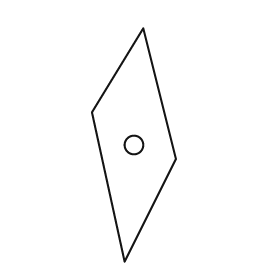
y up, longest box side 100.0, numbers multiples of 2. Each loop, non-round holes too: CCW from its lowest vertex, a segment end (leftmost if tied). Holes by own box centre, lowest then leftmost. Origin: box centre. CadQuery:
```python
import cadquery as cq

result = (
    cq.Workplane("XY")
    .moveTo(-4.0, -50.0)
    .lineTo(18.0, -6.0)
    .lineTo(4.0, 50.0)
    .lineTo(-18.0, 14.0)
    .close()
    .moveTo(0.0, 0.0)
    .circle(4.0)
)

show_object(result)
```